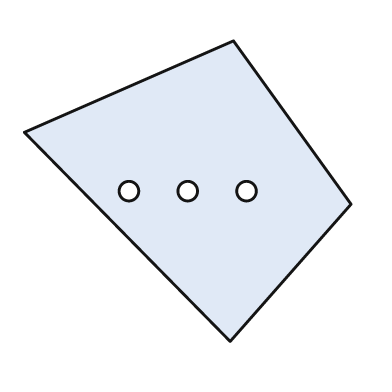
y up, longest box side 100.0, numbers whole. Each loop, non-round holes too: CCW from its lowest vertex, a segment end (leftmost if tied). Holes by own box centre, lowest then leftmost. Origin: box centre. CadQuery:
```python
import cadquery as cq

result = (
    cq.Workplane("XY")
    .moveTo(13.0, -46.0)
    .lineTo(50.0, -4.0)
    .lineTo(14.0, 46.0)
    .lineTo(-50.0, 18.0)
    .close()
    .moveTo(-18.0, 0.0)
    .circle(3.0)
    .moveTo(0.0, 0.0)
    .circle(3.0)
    .moveTo(18.0, 0.0)
    .circle(3.0)
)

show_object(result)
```